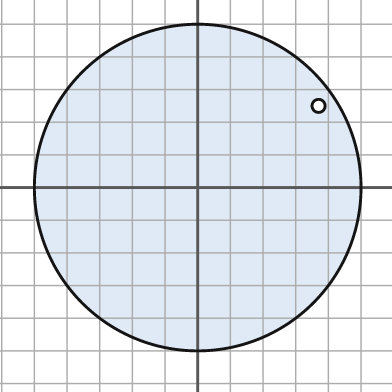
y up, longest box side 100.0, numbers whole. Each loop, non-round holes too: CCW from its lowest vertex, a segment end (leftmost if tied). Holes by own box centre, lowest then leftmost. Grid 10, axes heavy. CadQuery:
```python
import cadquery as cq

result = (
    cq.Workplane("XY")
    .moveTo(0.0, 0.0)
    .circle(50.0)
    .moveTo(37.0, 25.0)
    .circle(2.0)
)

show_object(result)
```